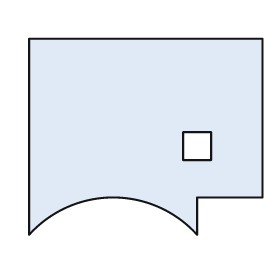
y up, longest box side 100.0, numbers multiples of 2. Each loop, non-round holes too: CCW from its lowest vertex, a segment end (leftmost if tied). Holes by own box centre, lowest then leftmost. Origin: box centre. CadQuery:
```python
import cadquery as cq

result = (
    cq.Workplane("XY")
    .moveTo(-50.0, -42.0)
    .threePointArc((-14.0, -26.0), (22.0, -42.0))
    .lineTo(22.0, -26.0)
    .lineTo(50.0, -26.0)
    .lineTo(50.0, 42.0)
    .lineTo(-50.0, 42.0)
    .close()
    .moveTo(16.0, -10.0)
    .lineTo(28.0, -10.0)
    .lineTo(28.0, 2.0)
    .lineTo(16.0, 2.0)
    .close()
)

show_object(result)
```